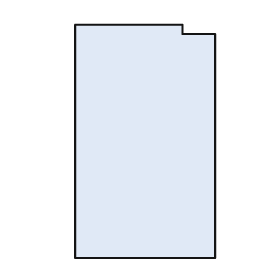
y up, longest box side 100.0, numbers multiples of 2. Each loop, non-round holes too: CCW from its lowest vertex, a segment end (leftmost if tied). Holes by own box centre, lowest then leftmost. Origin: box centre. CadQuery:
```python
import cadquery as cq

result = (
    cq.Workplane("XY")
    .moveTo(-30.0, -50.0)
    .lineTo(30.0, -50.0)
    .lineTo(30.0, 46.0)
    .lineTo(16.0, 46.0)
    .lineTo(16.0, 50.0)
    .lineTo(-30.0, 50.0)
    .close()
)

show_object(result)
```